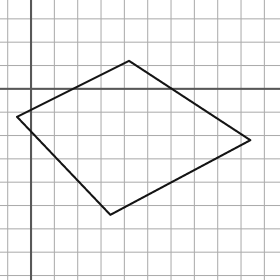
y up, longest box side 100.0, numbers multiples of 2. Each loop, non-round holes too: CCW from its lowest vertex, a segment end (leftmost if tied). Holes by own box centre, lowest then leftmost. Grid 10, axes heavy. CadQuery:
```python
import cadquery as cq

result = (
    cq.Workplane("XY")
    .moveTo(34.0, -54.0)
    .lineTo(94.0, -22.0)
    .lineTo(42.0, 12.0)
    .lineTo(-6.0, -12.0)
    .close()
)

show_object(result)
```